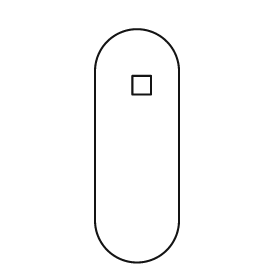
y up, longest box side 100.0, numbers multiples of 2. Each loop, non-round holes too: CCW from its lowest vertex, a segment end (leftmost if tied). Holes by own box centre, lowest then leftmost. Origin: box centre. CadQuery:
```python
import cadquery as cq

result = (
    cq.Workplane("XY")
    .moveTo(-18.0, -32.0)
    .threePointArc((0.0, -50.0), (18.0, -32.0))
    .lineTo(18.0, 32.0)
    .threePointArc((0.0, 50.0), (-18.0, 32.0))
    .close()
    .moveTo(-2.0, 22.0)
    .lineTo(6.0, 22.0)
    .lineTo(6.0, 30.0)
    .lineTo(-2.0, 30.0)
    .close()
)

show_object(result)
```